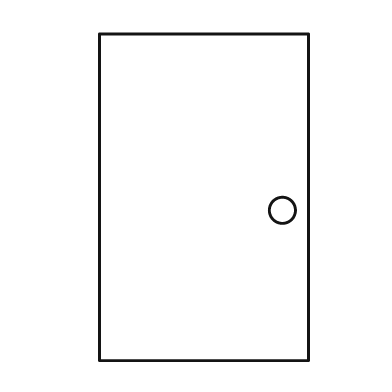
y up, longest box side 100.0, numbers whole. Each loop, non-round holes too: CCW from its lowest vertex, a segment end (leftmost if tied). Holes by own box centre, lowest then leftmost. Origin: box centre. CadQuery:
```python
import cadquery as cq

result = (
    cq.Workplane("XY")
    .moveTo(-32.0, -50.0)
    .lineTo(32.0, -50.0)
    .lineTo(32.0, 50.0)
    .lineTo(-32.0, 50.0)
    .close()
    .moveTo(24.0, -4.0)
    .circle(4.0)
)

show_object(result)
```